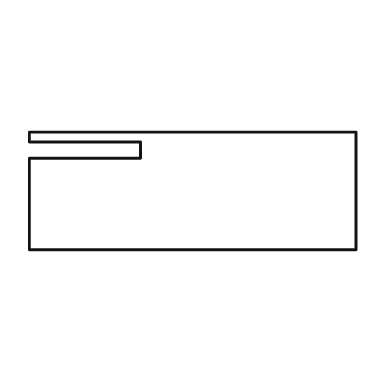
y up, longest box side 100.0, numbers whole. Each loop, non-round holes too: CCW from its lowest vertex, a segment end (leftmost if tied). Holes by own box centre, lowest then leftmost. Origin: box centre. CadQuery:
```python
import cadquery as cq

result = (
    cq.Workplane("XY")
    .moveTo(-50.0, -18.0)
    .lineTo(50.0, -18.0)
    .lineTo(50.0, 18.0)
    .lineTo(-50.0, 18.0)
    .lineTo(-50.0, 15.0)
    .lineTo(-16.0, 15.0)
    .lineTo(-16.0, 10.0)
    .lineTo(-50.0, 10.0)
    .close()
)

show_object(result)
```